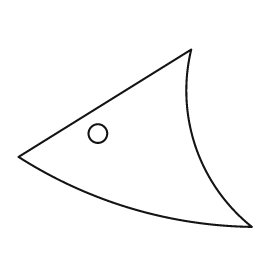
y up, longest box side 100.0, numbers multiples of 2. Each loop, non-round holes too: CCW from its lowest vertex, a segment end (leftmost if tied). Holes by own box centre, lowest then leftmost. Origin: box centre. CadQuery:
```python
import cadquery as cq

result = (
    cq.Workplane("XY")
    .moveTo(50.0, -38.0)
    .threePointArc((26.0, -4.0), (24.0, 38.0))
    .lineTo(-50.0, -8.0)
    .threePointArc((-2.0, -30.0), (50.0, -38.0))
    .close()
    .moveTo(-16.0, 2.0)
    .circle(4.0)
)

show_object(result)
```